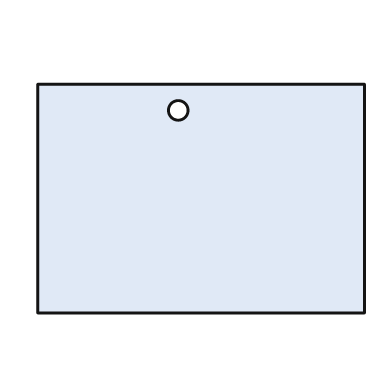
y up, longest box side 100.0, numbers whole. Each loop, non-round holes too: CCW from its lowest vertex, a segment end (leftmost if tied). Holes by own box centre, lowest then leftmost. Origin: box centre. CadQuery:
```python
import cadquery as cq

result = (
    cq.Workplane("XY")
    .moveTo(-50.0, -35.0)
    .lineTo(50.0, -35.0)
    .lineTo(50.0, 35.0)
    .lineTo(-50.0, 35.0)
    .close()
    .moveTo(-7.0, 27.0)
    .circle(3.0)
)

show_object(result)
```